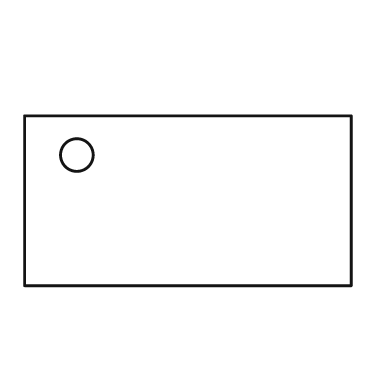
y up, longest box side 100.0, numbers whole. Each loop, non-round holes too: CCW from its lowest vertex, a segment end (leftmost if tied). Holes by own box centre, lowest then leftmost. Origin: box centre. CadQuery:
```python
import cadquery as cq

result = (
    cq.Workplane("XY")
    .moveTo(-50.0, -26.0)
    .lineTo(50.0, -26.0)
    .lineTo(50.0, 26.0)
    .lineTo(-50.0, 26.0)
    .close()
    .moveTo(-34.0, 14.0)
    .circle(5.0)
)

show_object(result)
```